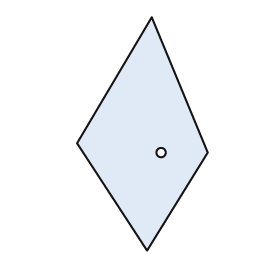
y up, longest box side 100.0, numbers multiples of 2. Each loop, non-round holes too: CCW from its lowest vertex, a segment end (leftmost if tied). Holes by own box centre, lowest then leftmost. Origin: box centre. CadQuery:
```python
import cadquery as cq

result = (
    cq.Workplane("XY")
    .moveTo(2.0, -50.0)
    .lineTo(28.0, -8.0)
    .lineTo(4.0, 50.0)
    .lineTo(-28.0, -4.0)
    .close()
    .moveTo(8.0, -8.0)
    .circle(2.0)
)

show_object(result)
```